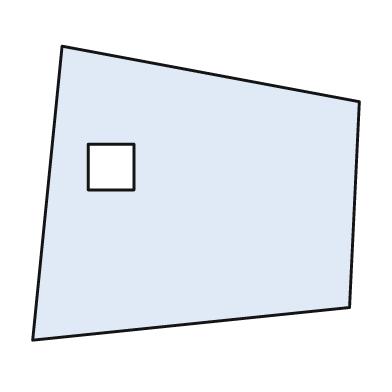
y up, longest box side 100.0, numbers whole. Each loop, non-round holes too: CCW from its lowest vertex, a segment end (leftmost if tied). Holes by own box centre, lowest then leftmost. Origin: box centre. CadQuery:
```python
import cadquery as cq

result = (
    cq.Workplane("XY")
    .moveTo(-50.0, -45.0)
    .lineTo(47.0, -35.0)
    .lineTo(50.0, 28.0)
    .lineTo(-41.0, 45.0)
    .close()
    .moveTo(-33.0, 1.0)
    .lineTo(-19.0, 1.0)
    .lineTo(-19.0, 15.0)
    .lineTo(-33.0, 15.0)
    .close()
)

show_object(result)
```